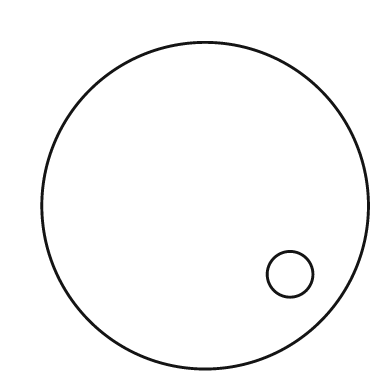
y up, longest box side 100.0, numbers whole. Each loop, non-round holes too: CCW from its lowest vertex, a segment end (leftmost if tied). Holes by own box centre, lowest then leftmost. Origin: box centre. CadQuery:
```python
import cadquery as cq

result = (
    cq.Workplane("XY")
    .moveTo(0.0, 0.0)
    .circle(50.0)
    .moveTo(26.0, -21.0)
    .circle(7.0)
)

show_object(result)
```